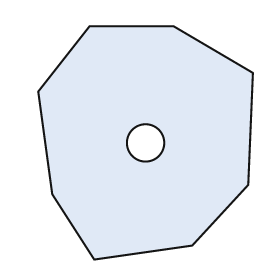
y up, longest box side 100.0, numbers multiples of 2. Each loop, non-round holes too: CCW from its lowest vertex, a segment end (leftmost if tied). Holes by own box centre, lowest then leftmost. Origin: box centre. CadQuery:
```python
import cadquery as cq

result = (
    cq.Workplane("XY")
    .moveTo(-22.0, -50.0)
    .lineTo(20.0, -44.0)
    .lineTo(44.0, -18.0)
    .lineTo(46.0, 30.0)
    .lineTo(12.0, 50.0)
    .lineTo(-24.0, 50.0)
    .lineTo(-46.0, 22.0)
    .lineTo(-40.0, -22.0)
    .close()
    .moveTo(0.0, 0.0)
    .circle(8.0)
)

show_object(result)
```